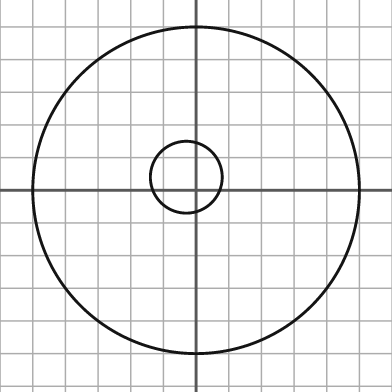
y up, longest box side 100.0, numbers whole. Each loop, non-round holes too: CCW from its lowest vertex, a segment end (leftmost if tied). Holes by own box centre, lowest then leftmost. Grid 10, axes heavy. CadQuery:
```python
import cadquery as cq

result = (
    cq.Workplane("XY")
    .moveTo(0.0, 0.0)
    .circle(50.0)
    .moveTo(-3.0, 4.0)
    .circle(11.0)
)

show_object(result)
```